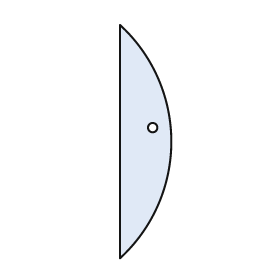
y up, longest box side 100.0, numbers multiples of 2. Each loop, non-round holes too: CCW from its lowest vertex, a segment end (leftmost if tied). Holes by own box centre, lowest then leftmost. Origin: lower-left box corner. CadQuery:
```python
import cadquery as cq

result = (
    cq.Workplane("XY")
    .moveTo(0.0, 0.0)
    .threePointArc((22.0, 50.0), (0.0, 100.0))
    .close()
    .moveTo(14.0, 56.0)
    .circle(2.0)
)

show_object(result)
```